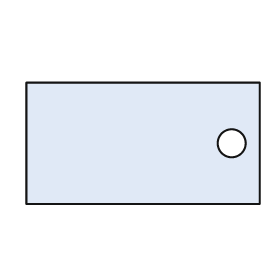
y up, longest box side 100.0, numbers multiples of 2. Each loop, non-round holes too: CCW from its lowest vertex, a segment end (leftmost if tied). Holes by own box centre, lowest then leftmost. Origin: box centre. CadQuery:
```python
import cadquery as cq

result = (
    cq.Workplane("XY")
    .moveTo(-50.0, -26.0)
    .lineTo(50.0, -26.0)
    .lineTo(50.0, 26.0)
    .lineTo(-50.0, 26.0)
    .close()
    .moveTo(38.0, 0.0)
    .circle(6.0)
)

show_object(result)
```